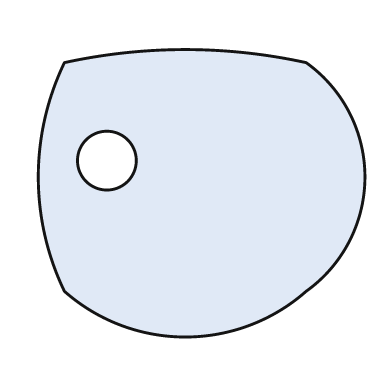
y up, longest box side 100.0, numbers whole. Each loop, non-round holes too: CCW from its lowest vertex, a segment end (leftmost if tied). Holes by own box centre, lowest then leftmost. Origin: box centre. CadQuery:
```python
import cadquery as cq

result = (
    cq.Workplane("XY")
    .moveTo(-42.0, -30.0)
    .threePointArc((-5.0, -44.0), (32.0, -30.0))
    .threePointArc((50.0, 5.0), (32.0, 40.0))
    .threePointArc((-5.0, 44.0), (-42.0, 40.0))
    .threePointArc((-50.0, 5.0), (-42.0, -30.0))
    .close()
    .moveTo(-29.0, 10.0)
    .circle(9.0)
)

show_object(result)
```